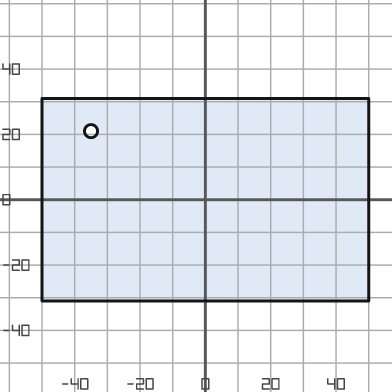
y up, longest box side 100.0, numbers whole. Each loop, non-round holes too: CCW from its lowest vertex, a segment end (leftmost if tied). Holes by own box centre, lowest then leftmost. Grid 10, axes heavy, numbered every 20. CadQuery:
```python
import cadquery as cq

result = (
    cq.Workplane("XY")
    .moveTo(-50.0, -31.0)
    .lineTo(50.0, -31.0)
    .lineTo(50.0, 31.0)
    .lineTo(-50.0, 31.0)
    .close()
    .moveTo(-35.0, 21.0)
    .circle(2.0)
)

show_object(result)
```